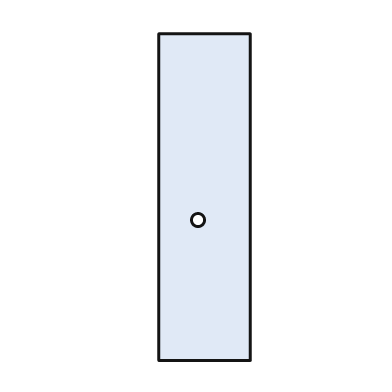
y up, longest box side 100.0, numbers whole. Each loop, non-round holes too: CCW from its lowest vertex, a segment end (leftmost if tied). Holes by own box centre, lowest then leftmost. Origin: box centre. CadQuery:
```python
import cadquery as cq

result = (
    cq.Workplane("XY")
    .moveTo(-14.0, -50.0)
    .lineTo(14.0, -50.0)
    .lineTo(14.0, 50.0)
    .lineTo(-14.0, 50.0)
    .close()
    .moveTo(-2.0, -7.0)
    .circle(2.0)
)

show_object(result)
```